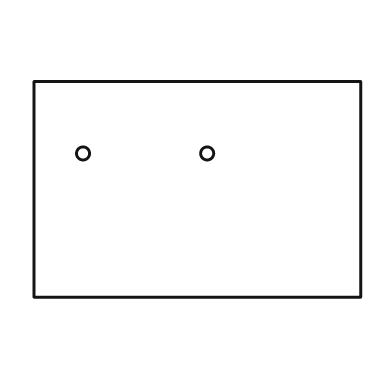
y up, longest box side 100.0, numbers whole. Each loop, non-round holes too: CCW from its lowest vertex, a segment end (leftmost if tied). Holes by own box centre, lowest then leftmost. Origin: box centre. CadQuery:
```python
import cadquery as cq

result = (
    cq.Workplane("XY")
    .moveTo(-50.0, -33.0)
    .lineTo(50.0, -33.0)
    .lineTo(50.0, 33.0)
    .lineTo(-50.0, 33.0)
    .close()
    .moveTo(-35.0, 11.0)
    .circle(2.0)
    .moveTo(3.0, 11.0)
    .circle(2.0)
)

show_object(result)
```